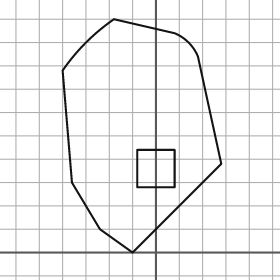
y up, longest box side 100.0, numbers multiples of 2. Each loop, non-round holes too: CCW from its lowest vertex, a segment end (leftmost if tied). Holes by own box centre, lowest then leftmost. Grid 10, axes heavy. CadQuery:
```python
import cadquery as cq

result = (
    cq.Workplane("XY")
    .moveTo(-10.0, 0.0)
    .lineTo(28.0, 38.0)
    .lineTo(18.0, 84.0)
    .threePointArc((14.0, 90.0), (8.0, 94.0))
    .lineTo(-18.0, 100.0)
    .threePointArc((-30.0, 90.0), (-40.0, 78.0))
    .lineTo(-36.0, 30.0)
    .lineTo(-24.0, 10.0)
    .close()
    .moveTo(-8.0, 28.0)
    .lineTo(8.0, 28.0)
    .lineTo(8.0, 44.0)
    .lineTo(-8.0, 44.0)
    .close()
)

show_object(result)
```